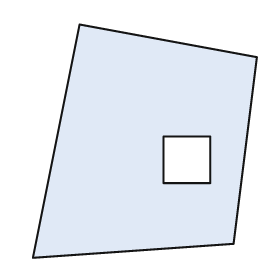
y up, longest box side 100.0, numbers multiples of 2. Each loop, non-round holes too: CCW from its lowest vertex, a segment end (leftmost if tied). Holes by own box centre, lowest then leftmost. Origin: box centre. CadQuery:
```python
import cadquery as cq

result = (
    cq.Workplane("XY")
    .moveTo(-48.0, -50.0)
    .lineTo(38.0, -44.0)
    .lineTo(48.0, 36.0)
    .lineTo(-28.0, 50.0)
    .close()
    .moveTo(8.0, -18.0)
    .lineTo(28.0, -18.0)
    .lineTo(28.0, 2.0)
    .lineTo(8.0, 2.0)
    .close()
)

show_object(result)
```